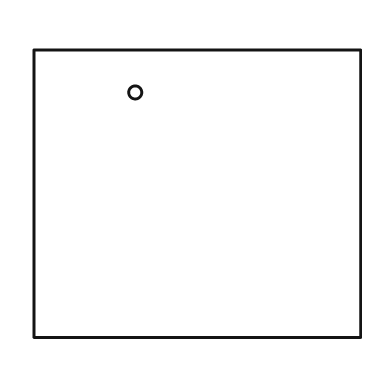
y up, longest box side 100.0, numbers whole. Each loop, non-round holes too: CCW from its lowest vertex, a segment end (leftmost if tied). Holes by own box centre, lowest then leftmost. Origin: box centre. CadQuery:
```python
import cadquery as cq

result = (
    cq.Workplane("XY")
    .moveTo(-50.0, -44.0)
    .lineTo(50.0, -44.0)
    .lineTo(50.0, 44.0)
    .lineTo(-50.0, 44.0)
    .close()
    .moveTo(-19.0, 31.0)
    .circle(2.0)
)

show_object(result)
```